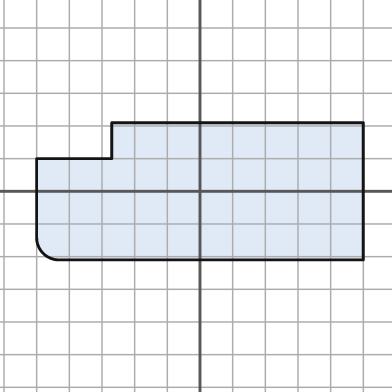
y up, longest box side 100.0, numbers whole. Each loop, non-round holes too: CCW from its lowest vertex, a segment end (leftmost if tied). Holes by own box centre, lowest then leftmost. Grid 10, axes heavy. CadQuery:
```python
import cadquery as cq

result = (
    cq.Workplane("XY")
    .moveTo(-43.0, -21.0)
    .lineTo(50.0, -21.0)
    .lineTo(50.0, 21.0)
    .lineTo(-27.0, 21.0)
    .lineTo(-27.0, 10.0)
    .lineTo(-50.0, 10.0)
    .lineTo(-50.0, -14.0)
    .threePointArc((-48.0, -19.0), (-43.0, -21.0))
    .close()
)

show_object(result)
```